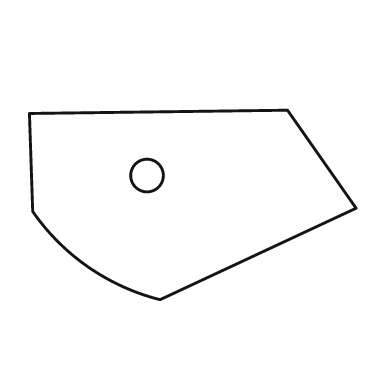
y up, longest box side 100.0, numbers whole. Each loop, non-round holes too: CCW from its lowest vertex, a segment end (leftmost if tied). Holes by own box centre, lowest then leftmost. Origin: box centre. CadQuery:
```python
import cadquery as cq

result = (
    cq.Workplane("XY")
    .moveTo(-10.0, -29.0)
    .lineTo(50.0, -1.0)
    .lineTo(29.0, 29.0)
    .lineTo(-50.0, 28.0)
    .lineTo(-49.0, -2.0)
    .threePointArc((-32.0, -19.0), (-10.0, -29.0))
    .close()
    .moveTo(-14.0, 9.0)
    .circle(5.0)
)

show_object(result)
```